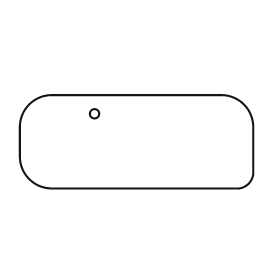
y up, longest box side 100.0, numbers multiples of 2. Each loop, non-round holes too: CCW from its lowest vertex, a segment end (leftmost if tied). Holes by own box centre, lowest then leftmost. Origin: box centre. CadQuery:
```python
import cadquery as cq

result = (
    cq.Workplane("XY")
    .moveTo(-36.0, -20.0)
    .lineTo(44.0, -20.0)
    .threePointArc((48.0, -18.0), (50.0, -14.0))
    .lineTo(50.0, 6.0)
    .threePointArc((46.0, 16.0), (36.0, 20.0))
    .lineTo(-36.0, 20.0)
    .threePointArc((-46.0, 16.0), (-50.0, 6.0))
    .lineTo(-50.0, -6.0)
    .threePointArc((-46.0, -16.0), (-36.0, -20.0))
    .close()
    .moveTo(-18.0, 12.0)
    .circle(2.0)
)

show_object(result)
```